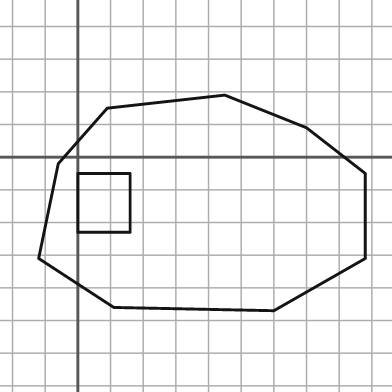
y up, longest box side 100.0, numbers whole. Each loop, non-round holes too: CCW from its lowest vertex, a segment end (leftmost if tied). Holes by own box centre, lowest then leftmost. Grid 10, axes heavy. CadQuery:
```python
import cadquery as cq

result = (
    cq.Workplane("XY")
    .moveTo(60.0, -47.0)
    .lineTo(88.0, -31.0)
    .lineTo(88.0, -5.0)
    .lineTo(70.0, 9.0)
    .lineTo(45.0, 19.0)
    .lineTo(9.0, 15.0)
    .lineTo(-6.0, -2.0)
    .lineTo(-12.0, -31.0)
    .lineTo(11.0, -46.0)
    .close()
    .moveTo(0.0, -23.0)
    .lineTo(16.0, -23.0)
    .lineTo(16.0, -5.0)
    .lineTo(0.0, -5.0)
    .close()
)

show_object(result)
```